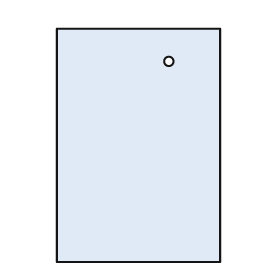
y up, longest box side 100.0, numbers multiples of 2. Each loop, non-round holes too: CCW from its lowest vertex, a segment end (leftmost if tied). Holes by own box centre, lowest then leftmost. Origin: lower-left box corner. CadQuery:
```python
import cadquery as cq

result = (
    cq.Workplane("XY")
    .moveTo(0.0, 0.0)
    .lineTo(70.0, 0.0)
    .lineTo(70.0, 100.0)
    .lineTo(0.0, 100.0)
    .close()
    .moveTo(48.0, 86.0)
    .circle(2.0)
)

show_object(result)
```